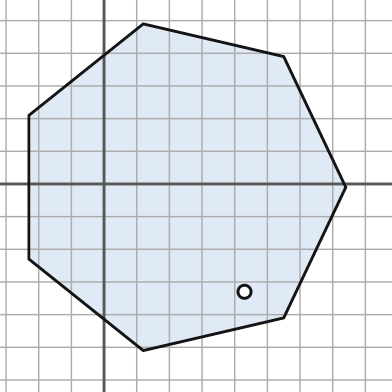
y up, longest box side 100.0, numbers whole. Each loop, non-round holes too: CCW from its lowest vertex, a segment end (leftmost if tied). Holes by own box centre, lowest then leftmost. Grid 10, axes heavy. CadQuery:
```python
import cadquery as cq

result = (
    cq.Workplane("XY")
    .moveTo(12.0, -51.0)
    .lineTo(55.0, -41.0)
    .lineTo(74.0, -1.0)
    .lineTo(55.0, 39.0)
    .lineTo(12.0, 49.0)
    .lineTo(-23.0, 21.0)
    .lineTo(-23.0, -23.0)
    .close()
    .moveTo(43.0, -33.0)
    .circle(2.0)
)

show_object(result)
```